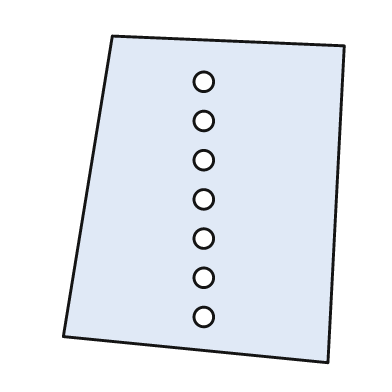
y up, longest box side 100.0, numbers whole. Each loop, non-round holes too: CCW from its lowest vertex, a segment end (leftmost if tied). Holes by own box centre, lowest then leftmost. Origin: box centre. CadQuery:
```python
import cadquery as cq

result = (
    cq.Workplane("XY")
    .moveTo(38.0, -50.0)
    .lineTo(43.0, 47.0)
    .lineTo(-28.0, 50.0)
    .lineTo(-43.0, -42.0)
    .close()
    .moveTo(0.0, -36.0)
    .circle(3.0)
    .moveTo(0.0, -24.0)
    .circle(3.0)
    .moveTo(0.0, -12.0)
    .circle(3.0)
    .moveTo(0.0, 0.0)
    .circle(3.0)
    .moveTo(0.0, 12.0)
    .circle(3.0)
    .moveTo(0.0, 24.0)
    .circle(3.0)
    .moveTo(0.0, 36.0)
    .circle(3.0)
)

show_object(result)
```